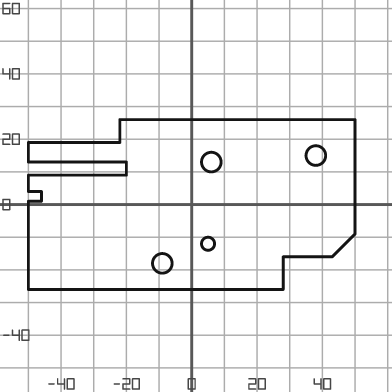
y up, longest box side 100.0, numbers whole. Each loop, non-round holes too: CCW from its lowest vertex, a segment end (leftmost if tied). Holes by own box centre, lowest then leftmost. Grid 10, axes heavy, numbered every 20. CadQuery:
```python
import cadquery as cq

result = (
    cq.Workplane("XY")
    .moveTo(-50.0, -26.0)
    .lineTo(28.0, -26.0)
    .lineTo(28.0, -16.0)
    .lineTo(43.0, -16.0)
    .lineTo(50.0, -9.0)
    .lineTo(50.0, 26.0)
    .lineTo(-22.0, 26.0)
    .lineTo(-22.0, 19.0)
    .lineTo(-50.0, 19.0)
    .lineTo(-50.0, 13.0)
    .lineTo(-20.0, 13.0)
    .lineTo(-20.0, 9.0)
    .lineTo(-50.0, 9.0)
    .lineTo(-50.0, 4.0)
    .lineTo(-46.0, 4.0)
    .lineTo(-46.0, 1.0)
    .lineTo(-50.0, 1.0)
    .close()
    .moveTo(-9.0, -18.0)
    .circle(3.0)
    .moveTo(5.0, -12.0)
    .circle(2.0)
    .moveTo(6.0, 13.0)
    .circle(3.0)
    .moveTo(38.0, 15.0)
    .circle(3.0)
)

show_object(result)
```